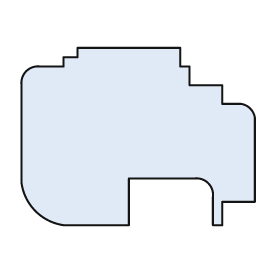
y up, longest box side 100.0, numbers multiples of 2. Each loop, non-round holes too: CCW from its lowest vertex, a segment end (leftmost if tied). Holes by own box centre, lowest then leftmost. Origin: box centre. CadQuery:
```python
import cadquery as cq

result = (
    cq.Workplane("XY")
    .moveTo(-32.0, -38.0)
    .lineTo(-4.0, -38.0)
    .lineTo(-4.0, -18.0)
    .lineTo(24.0, -18.0)
    .threePointArc((30.0, -20.0), (32.0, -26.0))
    .lineTo(32.0, -38.0)
    .lineTo(36.0, -38.0)
    .lineTo(36.0, -28.0)
    .lineTo(50.0, -28.0)
    .lineTo(50.0, 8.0)
    .threePointArc((48.0, 12.0), (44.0, 14.0))
    .lineTo(36.0, 14.0)
    .lineTo(36.0, 22.0)
    .lineTo(22.0, 22.0)
    .lineTo(22.0, 30.0)
    .lineTo(18.0, 30.0)
    .lineTo(18.0, 38.0)
    .lineTo(-26.0, 38.0)
    .lineTo(-26.0, 34.0)
    .lineTo(-32.0, 34.0)
    .lineTo(-32.0, 30.0)
    .lineTo(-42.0, 30.0)
    .threePointArc((-48.0, 28.0), (-50.0, 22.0))
    .lineTo(-50.0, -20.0)
    .threePointArc((-44.0, -32.0), (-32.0, -38.0))
    .close()
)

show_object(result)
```